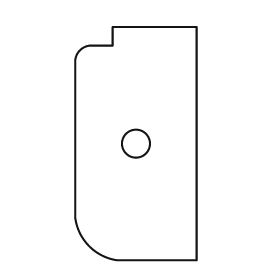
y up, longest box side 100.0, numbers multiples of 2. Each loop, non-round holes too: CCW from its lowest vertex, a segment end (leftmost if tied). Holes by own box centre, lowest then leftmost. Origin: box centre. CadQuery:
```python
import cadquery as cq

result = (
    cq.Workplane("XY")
    .moveTo(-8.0, -50.0)
    .lineTo(26.0, -50.0)
    .lineTo(26.0, 50.0)
    .lineTo(-10.0, 50.0)
    .lineTo(-10.0, 42.0)
    .lineTo(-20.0, 42.0)
    .threePointArc((-24.0, 40.0), (-26.0, 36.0))
    .lineTo(-26.0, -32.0)
    .threePointArc((-20.0, -44.0), (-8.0, -50.0))
    .close()
    .moveTo(0.0, 0.0)
    .circle(6.0)
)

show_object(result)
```